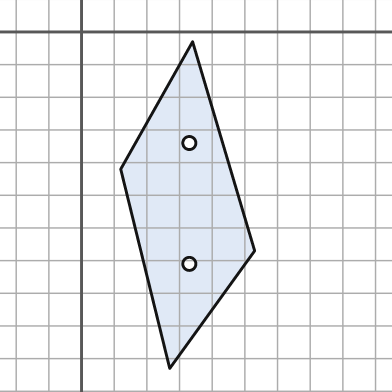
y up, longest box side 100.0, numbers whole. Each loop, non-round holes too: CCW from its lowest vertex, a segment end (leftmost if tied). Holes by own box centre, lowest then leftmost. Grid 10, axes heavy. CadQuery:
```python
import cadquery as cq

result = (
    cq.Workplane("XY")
    .moveTo(27.0, -103.0)
    .lineTo(53.0, -67.0)
    .lineTo(34.0, -3.0)
    .lineTo(12.0, -42.0)
    .close()
    .moveTo(33.0, -71.0)
    .circle(2.0)
    .moveTo(33.0, -34.0)
    .circle(2.0)
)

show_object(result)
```